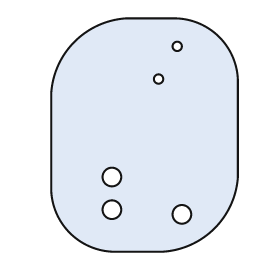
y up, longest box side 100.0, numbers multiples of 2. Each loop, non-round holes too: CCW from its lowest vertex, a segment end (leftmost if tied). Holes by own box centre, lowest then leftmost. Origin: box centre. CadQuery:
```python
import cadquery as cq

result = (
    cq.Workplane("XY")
    .moveTo(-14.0, -50.0)
    .lineTo(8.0, -50.0)
    .threePointArc((30.0, -40.0), (40.0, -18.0))
    .lineTo(40.0, 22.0)
    .threePointArc((32.0, 42.0), (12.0, 50.0))
    .lineTo(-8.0, 50.0)
    .threePointArc((-30.0, 40.0), (-40.0, 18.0))
    .lineTo(-40.0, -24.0)
    .threePointArc((-32.0, -42.0), (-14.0, -50.0))
    .close()
    .moveTo(16.0, -34.0)
    .circle(4.0)
    .moveTo(-14.0, -32.0)
    .circle(4.0)
    .moveTo(-14.0, -18.0)
    .circle(4.0)
    .moveTo(6.0, 24.0)
    .circle(2.0)
    .moveTo(14.0, 38.0)
    .circle(2.0)
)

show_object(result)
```